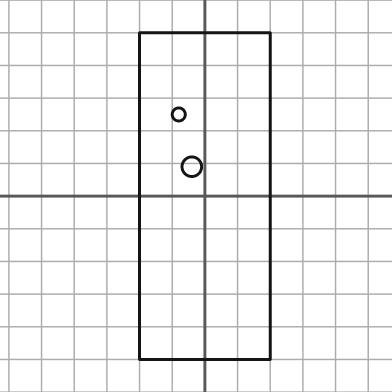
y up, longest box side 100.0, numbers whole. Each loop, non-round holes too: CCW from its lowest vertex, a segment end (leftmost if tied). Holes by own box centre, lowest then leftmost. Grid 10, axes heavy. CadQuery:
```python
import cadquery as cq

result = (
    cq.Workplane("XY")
    .moveTo(-20.0, -50.0)
    .lineTo(20.0, -50.0)
    .lineTo(20.0, 50.0)
    .lineTo(-20.0, 50.0)
    .close()
    .moveTo(-4.0, 9.0)
    .circle(3.0)
    .moveTo(-8.0, 25.0)
    .circle(2.0)
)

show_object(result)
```